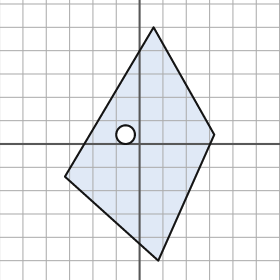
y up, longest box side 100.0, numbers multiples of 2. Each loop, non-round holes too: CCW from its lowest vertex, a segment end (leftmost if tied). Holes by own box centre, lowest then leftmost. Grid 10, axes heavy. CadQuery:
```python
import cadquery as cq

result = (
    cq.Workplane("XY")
    .moveTo(8.0, -50.0)
    .lineTo(32.0, 4.0)
    .lineTo(6.0, 50.0)
    .lineTo(-32.0, -14.0)
    .close()
    .moveTo(-6.0, 4.0)
    .circle(4.0)
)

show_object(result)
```